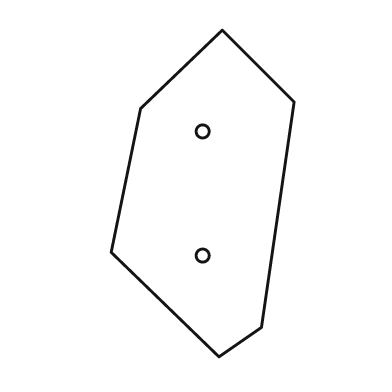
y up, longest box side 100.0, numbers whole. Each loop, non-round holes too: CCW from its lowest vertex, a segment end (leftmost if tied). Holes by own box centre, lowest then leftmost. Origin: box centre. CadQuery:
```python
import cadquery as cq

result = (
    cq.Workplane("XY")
    .moveTo(5.0, -50.0)
    .lineTo(18.0, -41.0)
    .lineTo(28.0, 28.0)
    .lineTo(6.0, 50.0)
    .lineTo(-19.0, 26.0)
    .lineTo(-28.0, -18.0)
    .close()
    .moveTo(0.0, -19.0)
    .circle(2.0)
    .moveTo(0.0, 19.0)
    .circle(2.0)
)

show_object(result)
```